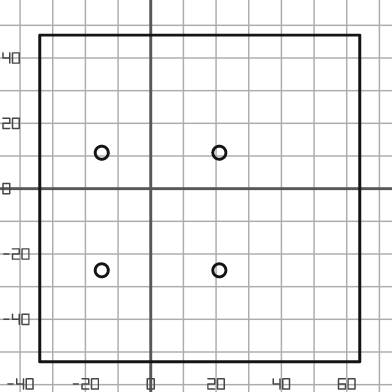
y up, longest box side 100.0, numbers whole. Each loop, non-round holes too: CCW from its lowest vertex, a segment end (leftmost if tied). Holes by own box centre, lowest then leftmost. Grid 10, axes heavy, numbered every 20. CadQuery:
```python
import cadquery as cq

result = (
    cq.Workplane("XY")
    .moveTo(-34.0, -53.0)
    .lineTo(64.0, -53.0)
    .lineTo(64.0, 47.0)
    .lineTo(-34.0, 47.0)
    .close()
    .moveTo(-15.0, -25.0)
    .circle(2.0)
    .moveTo(21.0, -25.0)
    .circle(2.0)
    .moveTo(-15.0, 11.0)
    .circle(2.0)
    .moveTo(21.0, 11.0)
    .circle(2.0)
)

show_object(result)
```